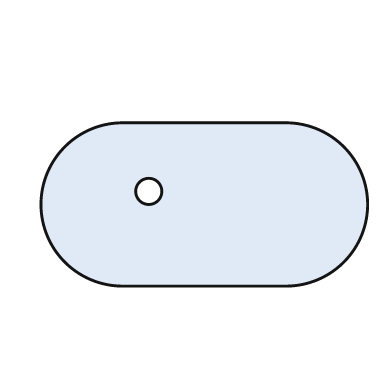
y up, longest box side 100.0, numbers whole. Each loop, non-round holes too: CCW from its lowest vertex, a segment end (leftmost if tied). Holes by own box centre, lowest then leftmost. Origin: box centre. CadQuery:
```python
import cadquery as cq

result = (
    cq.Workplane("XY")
    .moveTo(-25.0, -25.0)
    .lineTo(25.0, -25.0)
    .threePointArc((50.0, 0.0), (25.0, 25.0))
    .lineTo(-25.0, 25.0)
    .threePointArc((-50.0, 0.0), (-25.0, -25.0))
    .close()
    .moveTo(-17.0, 4.0)
    .circle(4.0)
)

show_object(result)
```